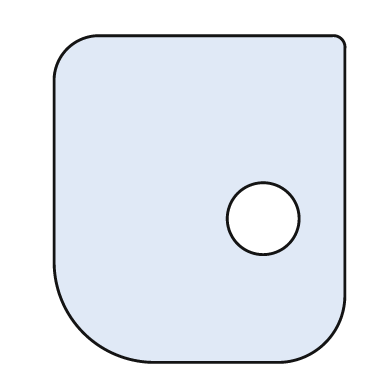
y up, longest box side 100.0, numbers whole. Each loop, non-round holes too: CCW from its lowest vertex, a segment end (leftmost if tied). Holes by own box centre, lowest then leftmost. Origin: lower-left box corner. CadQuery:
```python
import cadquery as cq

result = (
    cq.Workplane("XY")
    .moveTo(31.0, 0.0)
    .lineTo(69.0, 0.0)
    .threePointArc((83.0, 6.0), (89.0, 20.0))
    .lineTo(89.0, 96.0)
    .threePointArc((88.0, 99.0), (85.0, 100.0))
    .lineTo(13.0, 100.0)
    .threePointArc((4.0, 96.0), (0.0, 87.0))
    .lineTo(0.0, 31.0)
    .threePointArc((9.0, 9.0), (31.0, 0.0))
    .close()
    .moveTo(64.0, 44.0)
    .circle(11.0)
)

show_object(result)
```